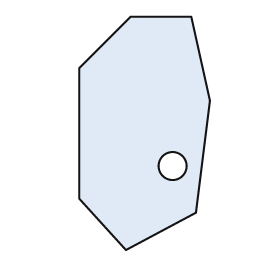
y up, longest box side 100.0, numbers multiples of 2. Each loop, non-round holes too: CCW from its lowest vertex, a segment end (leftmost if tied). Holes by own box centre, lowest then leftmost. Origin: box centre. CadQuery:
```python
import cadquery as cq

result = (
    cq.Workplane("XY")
    .moveTo(-8.0, -50.0)
    .lineTo(22.0, -34.0)
    .lineTo(28.0, 14.0)
    .lineTo(20.0, 50.0)
    .lineTo(-6.0, 50.0)
    .lineTo(-28.0, 28.0)
    .lineTo(-28.0, -28.0)
    .close()
    .moveTo(12.0, -14.0)
    .circle(6.0)
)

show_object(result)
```